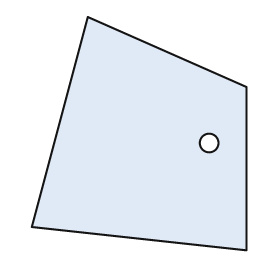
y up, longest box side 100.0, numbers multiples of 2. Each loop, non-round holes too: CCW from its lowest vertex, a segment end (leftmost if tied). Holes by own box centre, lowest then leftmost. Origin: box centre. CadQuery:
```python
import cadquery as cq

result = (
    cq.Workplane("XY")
    .moveTo(46.0, -50.0)
    .lineTo(46.0, 20.0)
    .lineTo(-22.0, 50.0)
    .lineTo(-46.0, -40.0)
    .close()
    .moveTo(30.0, -4.0)
    .circle(4.0)
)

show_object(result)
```